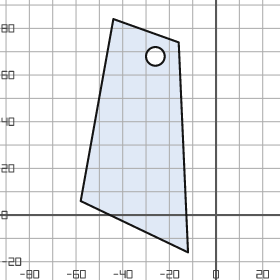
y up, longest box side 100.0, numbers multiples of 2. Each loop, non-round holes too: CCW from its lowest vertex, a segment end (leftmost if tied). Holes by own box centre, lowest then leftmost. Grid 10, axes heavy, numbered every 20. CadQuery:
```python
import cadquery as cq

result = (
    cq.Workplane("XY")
    .moveTo(-12.0, -16.0)
    .lineTo(-16.0, 74.0)
    .lineTo(-44.0, 84.0)
    .lineTo(-58.0, 6.0)
    .close()
    .moveTo(-26.0, 68.0)
    .circle(4.0)
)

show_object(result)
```